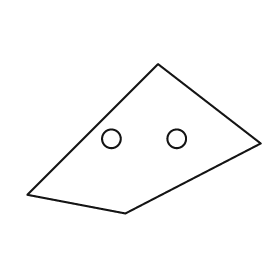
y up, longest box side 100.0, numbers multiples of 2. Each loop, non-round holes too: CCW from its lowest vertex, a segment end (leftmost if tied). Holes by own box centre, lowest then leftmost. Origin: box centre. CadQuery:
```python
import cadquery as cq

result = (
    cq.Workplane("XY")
    .moveTo(-8.0, -32.0)
    .lineTo(50.0, -2.0)
    .lineTo(6.0, 32.0)
    .lineTo(-50.0, -24.0)
    .close()
    .moveTo(-14.0, 0.0)
    .circle(4.0)
    .moveTo(14.0, 0.0)
    .circle(4.0)
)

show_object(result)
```